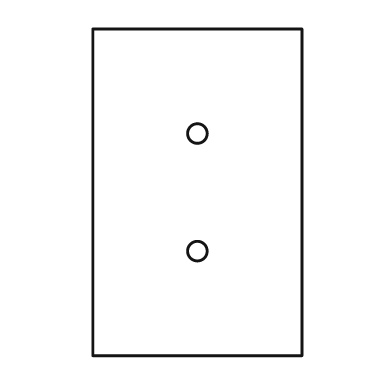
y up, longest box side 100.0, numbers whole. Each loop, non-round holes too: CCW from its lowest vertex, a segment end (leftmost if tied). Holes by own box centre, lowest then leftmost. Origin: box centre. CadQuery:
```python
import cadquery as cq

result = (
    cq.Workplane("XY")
    .moveTo(-32.0, -50.0)
    .lineTo(32.0, -50.0)
    .lineTo(32.0, 50.0)
    .lineTo(-32.0, 50.0)
    .close()
    .moveTo(0.0, -18.0)
    .circle(3.0)
    .moveTo(0.0, 18.0)
    .circle(3.0)
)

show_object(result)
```